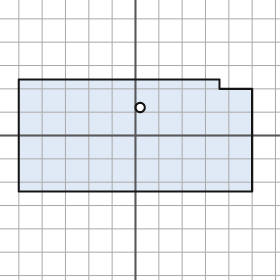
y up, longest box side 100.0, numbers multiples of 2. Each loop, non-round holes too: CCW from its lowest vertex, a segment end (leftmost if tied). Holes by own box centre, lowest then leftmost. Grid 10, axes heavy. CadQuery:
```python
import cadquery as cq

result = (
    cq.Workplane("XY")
    .moveTo(-50.0, -24.0)
    .lineTo(50.0, -24.0)
    .lineTo(50.0, 20.0)
    .lineTo(36.0, 20.0)
    .lineTo(36.0, 24.0)
    .lineTo(-50.0, 24.0)
    .close()
    .moveTo(2.0, 12.0)
    .circle(2.0)
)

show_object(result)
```